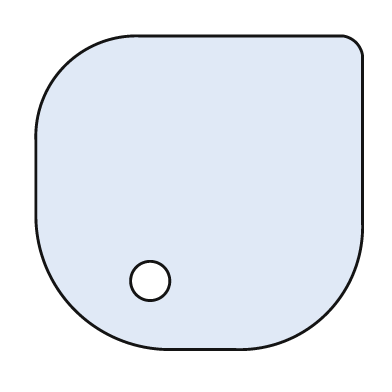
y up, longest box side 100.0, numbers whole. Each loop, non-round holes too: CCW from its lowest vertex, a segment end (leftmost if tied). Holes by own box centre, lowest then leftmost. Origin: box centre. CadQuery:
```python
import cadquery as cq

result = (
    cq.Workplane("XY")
    .moveTo(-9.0, -48.0)
    .lineTo(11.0, -48.0)
    .threePointArc((39.0, -37.0), (50.0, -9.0))
    .lineTo(50.0, 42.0)
    .threePointArc((48.0, 46.0), (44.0, 48.0))
    .lineTo(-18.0, 48.0)
    .threePointArc((-41.0, 39.0), (-50.0, 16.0))
    .lineTo(-50.0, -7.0)
    .threePointArc((-38.0, -36.0), (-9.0, -48.0))
    .close()
    .moveTo(-15.0, -27.0)
    .circle(6.0)
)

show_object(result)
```